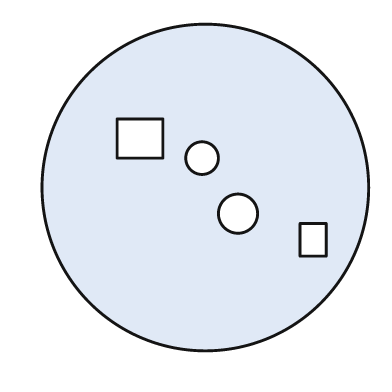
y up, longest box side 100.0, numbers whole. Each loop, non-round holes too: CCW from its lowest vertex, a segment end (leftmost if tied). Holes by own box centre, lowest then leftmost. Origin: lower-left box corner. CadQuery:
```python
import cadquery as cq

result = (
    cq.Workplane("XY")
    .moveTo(50.0, 50.0)
    .circle(50.0)
    .moveTo(79.0, 29.0)
    .lineTo(87.0, 29.0)
    .lineTo(87.0, 39.0)
    .lineTo(79.0, 39.0)
    .close()
    .moveTo(60.0, 42.0)
    .circle(6.0)
    .moveTo(49.0, 59.0)
    .circle(5.0)
    .moveTo(23.0, 59.0)
    .lineTo(37.0, 59.0)
    .lineTo(37.0, 71.0)
    .lineTo(23.0, 71.0)
    .close()
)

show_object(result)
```